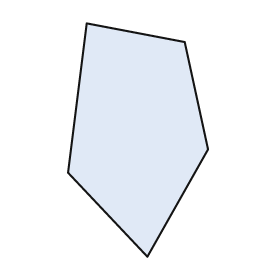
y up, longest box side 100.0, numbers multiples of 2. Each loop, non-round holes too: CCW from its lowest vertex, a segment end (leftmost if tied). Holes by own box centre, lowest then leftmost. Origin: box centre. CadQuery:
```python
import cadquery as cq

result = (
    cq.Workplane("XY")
    .moveTo(4.0, -50.0)
    .lineTo(30.0, -4.0)
    .lineTo(20.0, 42.0)
    .lineTo(-22.0, 50.0)
    .lineTo(-30.0, -14.0)
    .close()
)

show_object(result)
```